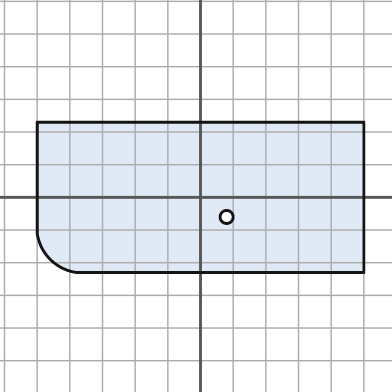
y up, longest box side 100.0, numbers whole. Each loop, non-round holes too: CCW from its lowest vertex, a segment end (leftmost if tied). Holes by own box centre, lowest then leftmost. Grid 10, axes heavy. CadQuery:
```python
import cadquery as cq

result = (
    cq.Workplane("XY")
    .moveTo(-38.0, -23.0)
    .lineTo(50.0, -23.0)
    .lineTo(50.0, 23.0)
    .lineTo(-50.0, 23.0)
    .lineTo(-50.0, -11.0)
    .threePointArc((-46.0, -19.0), (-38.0, -23.0))
    .close()
    .moveTo(8.0, -6.0)
    .circle(2.0)
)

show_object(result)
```